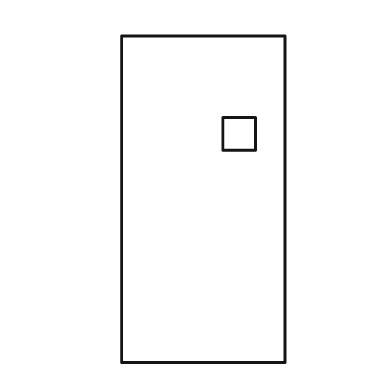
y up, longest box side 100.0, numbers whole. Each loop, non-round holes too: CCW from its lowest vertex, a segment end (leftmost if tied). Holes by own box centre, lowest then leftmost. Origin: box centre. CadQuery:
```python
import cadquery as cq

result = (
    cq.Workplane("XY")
    .moveTo(-25.0, -50.0)
    .lineTo(25.0, -50.0)
    .lineTo(25.0, 50.0)
    .lineTo(-25.0, 50.0)
    .close()
    .moveTo(6.0, 15.0)
    .lineTo(16.0, 15.0)
    .lineTo(16.0, 25.0)
    .lineTo(6.0, 25.0)
    .close()
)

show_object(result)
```